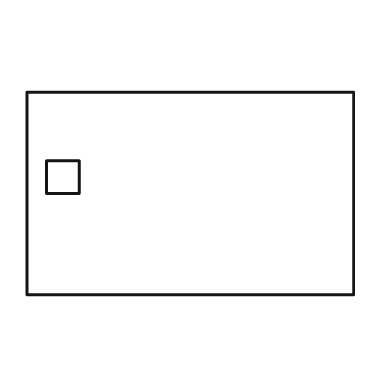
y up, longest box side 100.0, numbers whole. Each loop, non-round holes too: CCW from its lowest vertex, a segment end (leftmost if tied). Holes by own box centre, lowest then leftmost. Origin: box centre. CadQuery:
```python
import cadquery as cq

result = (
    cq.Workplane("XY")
    .moveTo(-50.0, -31.0)
    .lineTo(50.0, -31.0)
    .lineTo(50.0, 31.0)
    .lineTo(-50.0, 31.0)
    .close()
    .moveTo(-44.0, 0.0)
    .lineTo(-34.0, 0.0)
    .lineTo(-34.0, 10.0)
    .lineTo(-44.0, 10.0)
    .close()
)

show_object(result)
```